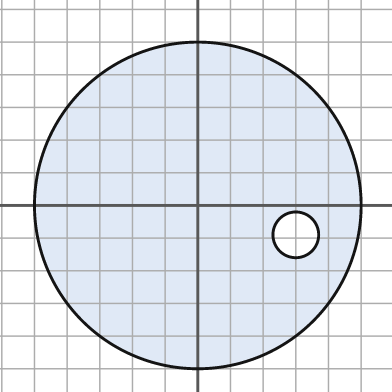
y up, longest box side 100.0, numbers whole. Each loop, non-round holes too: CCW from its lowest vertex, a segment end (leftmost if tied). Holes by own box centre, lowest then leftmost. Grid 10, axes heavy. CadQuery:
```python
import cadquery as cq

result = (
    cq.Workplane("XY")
    .moveTo(0.0, 0.0)
    .circle(50.0)
    .moveTo(30.0, -9.0)
    .circle(7.0)
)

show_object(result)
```